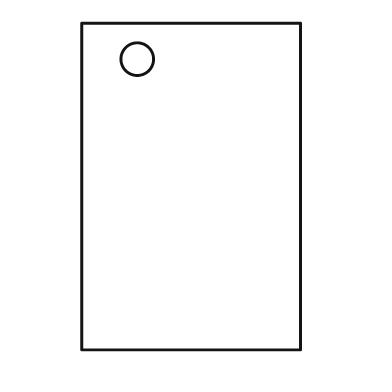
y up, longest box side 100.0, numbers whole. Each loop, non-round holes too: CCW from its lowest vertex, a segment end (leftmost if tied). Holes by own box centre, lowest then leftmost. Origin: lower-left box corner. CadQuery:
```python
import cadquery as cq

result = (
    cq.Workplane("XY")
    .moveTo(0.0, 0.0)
    .lineTo(67.0, 0.0)
    .lineTo(67.0, 100.0)
    .lineTo(0.0, 100.0)
    .close()
    .moveTo(17.0, 89.0)
    .circle(5.0)
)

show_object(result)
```